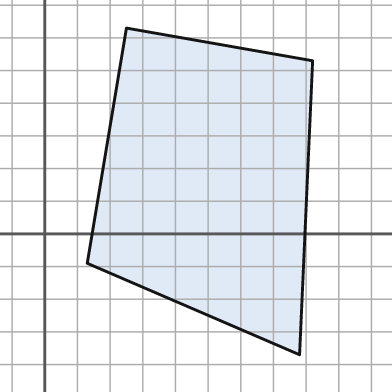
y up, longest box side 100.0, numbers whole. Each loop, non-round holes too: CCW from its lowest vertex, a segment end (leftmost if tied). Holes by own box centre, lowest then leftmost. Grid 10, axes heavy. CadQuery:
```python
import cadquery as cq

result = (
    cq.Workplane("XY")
    .moveTo(78.0, -37.0)
    .lineTo(82.0, 53.0)
    .lineTo(25.0, 63.0)
    .lineTo(13.0, -9.0)
    .close()
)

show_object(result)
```